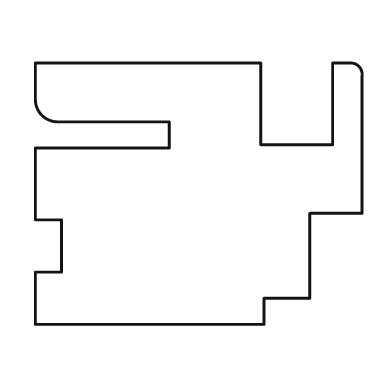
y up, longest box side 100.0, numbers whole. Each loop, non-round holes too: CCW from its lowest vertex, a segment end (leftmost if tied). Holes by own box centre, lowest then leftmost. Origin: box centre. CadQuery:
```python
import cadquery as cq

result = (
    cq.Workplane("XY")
    .moveTo(-50.0, -40.0)
    .lineTo(20.0, -40.0)
    .lineTo(20.0, -32.0)
    .lineTo(34.0, -32.0)
    .lineTo(34.0, -6.0)
    .lineTo(50.0, -6.0)
    .lineTo(50.0, 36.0)
    .threePointArc((49.0, 39.0), (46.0, 40.0))
    .lineTo(41.0, 40.0)
    .lineTo(41.0, 15.0)
    .lineTo(19.0, 15.0)
    .lineTo(19.0, 40.0)
    .lineTo(-50.0, 40.0)
    .lineTo(-50.0, 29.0)
    .threePointArc((-48.0, 24.0), (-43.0, 22.0))
    .lineTo(-9.0, 22.0)
    .lineTo(-9.0, 14.0)
    .lineTo(-50.0, 14.0)
    .lineTo(-50.0, -8.0)
    .lineTo(-42.0, -8.0)
    .lineTo(-42.0, -24.0)
    .lineTo(-50.0, -24.0)
    .close()
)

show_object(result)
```